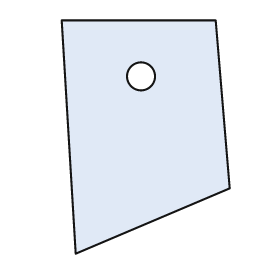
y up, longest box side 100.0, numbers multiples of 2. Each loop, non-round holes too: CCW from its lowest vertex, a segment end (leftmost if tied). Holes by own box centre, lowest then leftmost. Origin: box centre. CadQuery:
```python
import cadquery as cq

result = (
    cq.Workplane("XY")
    .moveTo(-30.0, -50.0)
    .lineTo(36.0, -22.0)
    .lineTo(30.0, 50.0)
    .lineTo(-36.0, 50.0)
    .close()
    .moveTo(-2.0, 26.0)
    .circle(6.0)
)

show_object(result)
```